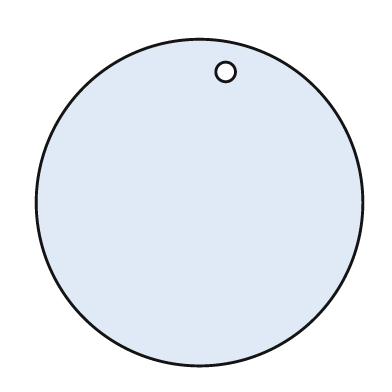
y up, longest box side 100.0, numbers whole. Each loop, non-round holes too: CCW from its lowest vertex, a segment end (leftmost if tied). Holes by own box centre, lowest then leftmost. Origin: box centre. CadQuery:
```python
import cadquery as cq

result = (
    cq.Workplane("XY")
    .moveTo(0.0, 0.0)
    .circle(50.0)
    .moveTo(8.0, 40.0)
    .circle(3.0)
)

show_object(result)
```